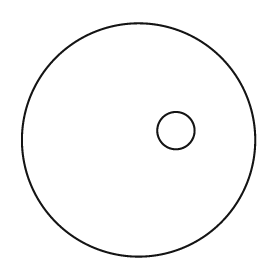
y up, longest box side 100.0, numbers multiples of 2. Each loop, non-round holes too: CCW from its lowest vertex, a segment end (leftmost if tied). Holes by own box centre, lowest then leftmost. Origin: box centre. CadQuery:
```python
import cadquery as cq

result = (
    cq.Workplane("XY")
    .moveTo(0.0, 0.0)
    .circle(50.0)
    .moveTo(16.0, 4.0)
    .circle(8.0)
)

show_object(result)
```